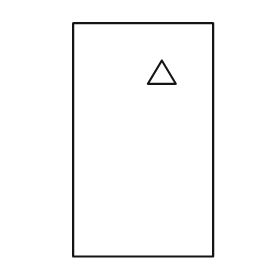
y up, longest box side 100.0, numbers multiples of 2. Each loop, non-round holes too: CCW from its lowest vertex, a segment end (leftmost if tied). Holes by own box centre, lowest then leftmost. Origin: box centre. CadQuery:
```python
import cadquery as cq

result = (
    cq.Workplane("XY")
    .moveTo(-30.0, -50.0)
    .lineTo(30.0, -50.0)
    .lineTo(30.0, 50.0)
    .lineTo(-30.0, 50.0)
    .close()
    .moveTo(2.0, 24.0)
    .lineTo(14.0, 24.0)
    .lineTo(8.0, 34.0)
    .close()
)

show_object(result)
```